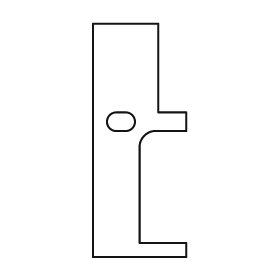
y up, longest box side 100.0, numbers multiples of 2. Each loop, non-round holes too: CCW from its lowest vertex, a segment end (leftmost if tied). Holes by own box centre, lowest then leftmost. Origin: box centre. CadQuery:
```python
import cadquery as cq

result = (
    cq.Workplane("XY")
    .moveTo(-20.0, -50.0)
    .lineTo(20.0, -50.0)
    .lineTo(20.0, -44.0)
    .lineTo(0.0, -44.0)
    .lineTo(0.0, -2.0)
    .threePointArc((2.0, 2.0), (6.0, 4.0))
    .lineTo(20.0, 4.0)
    .lineTo(20.0, 12.0)
    .lineTo(8.0, 12.0)
    .lineTo(8.0, 50.0)
    .lineTo(-20.0, 50.0)
    .close()
    .moveTo(-10.0, 4.0)
    .lineTo(-6.0, 4.0)
    .threePointArc((-2.0, 8.0), (-6.0, 12.0))
    .lineTo(-10.0, 12.0)
    .threePointArc((-14.0, 8.0), (-10.0, 4.0))
    .close()
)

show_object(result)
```